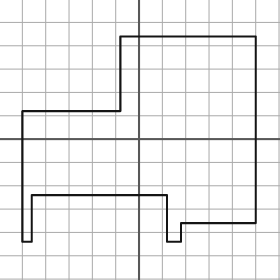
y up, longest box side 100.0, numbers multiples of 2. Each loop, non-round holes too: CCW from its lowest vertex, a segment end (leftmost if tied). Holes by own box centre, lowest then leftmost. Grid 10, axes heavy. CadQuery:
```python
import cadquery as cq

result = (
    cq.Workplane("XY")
    .moveTo(-50.0, -44.0)
    .lineTo(-46.0, -44.0)
    .lineTo(-46.0, -24.0)
    .lineTo(12.0, -24.0)
    .lineTo(12.0, -44.0)
    .lineTo(18.0, -44.0)
    .lineTo(18.0, -36.0)
    .lineTo(50.0, -36.0)
    .lineTo(50.0, 44.0)
    .lineTo(-8.0, 44.0)
    .lineTo(-8.0, 12.0)
    .lineTo(-50.0, 12.0)
    .close()
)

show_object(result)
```